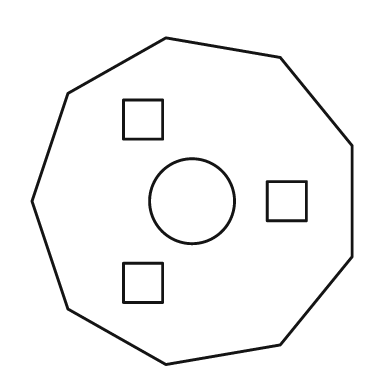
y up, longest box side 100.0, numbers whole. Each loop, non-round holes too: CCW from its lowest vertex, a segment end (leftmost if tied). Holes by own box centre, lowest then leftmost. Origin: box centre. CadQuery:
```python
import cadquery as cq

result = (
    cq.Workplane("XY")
    .moveTo(-8.0, -50.0)
    .lineTo(27.0, -44.0)
    .lineTo(49.0, -17.0)
    .lineTo(49.0, 17.0)
    .lineTo(27.0, 44.0)
    .lineTo(-8.0, 50.0)
    .lineTo(-38.0, 33.0)
    .lineTo(-49.0, 0.0)
    .lineTo(-38.0, -33.0)
    .close()
    .moveTo(-21.0, -31.0)
    .lineTo(-9.0, -31.0)
    .lineTo(-9.0, -19.0)
    .lineTo(-21.0, -19.0)
    .close()
    .moveTo(0.0, 0.0)
    .circle(13.0)
    .moveTo(23.0, -6.0)
    .lineTo(35.0, -6.0)
    .lineTo(35.0, 6.0)
    .lineTo(23.0, 6.0)
    .close()
    .moveTo(-21.0, 19.0)
    .lineTo(-9.0, 19.0)
    .lineTo(-9.0, 31.0)
    .lineTo(-21.0, 31.0)
    .close()
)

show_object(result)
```